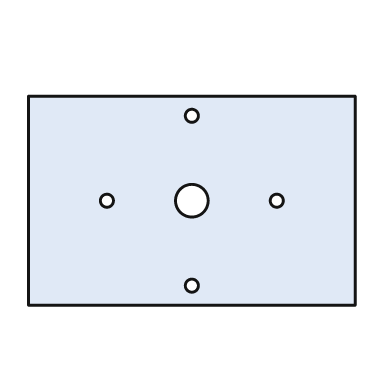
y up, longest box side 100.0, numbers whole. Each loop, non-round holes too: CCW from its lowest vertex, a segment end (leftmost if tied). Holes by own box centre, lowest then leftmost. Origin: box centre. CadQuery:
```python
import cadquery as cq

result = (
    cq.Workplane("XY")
    .moveTo(-50.0, -32.0)
    .lineTo(50.0, -32.0)
    .lineTo(50.0, 32.0)
    .lineTo(-50.0, 32.0)
    .close()
    .moveTo(0.0, -26.0)
    .circle(2.0)
    .moveTo(-26.0, 0.0)
    .circle(2.0)
    .moveTo(0.0, 0.0)
    .circle(5.0)
    .moveTo(26.0, 0.0)
    .circle(2.0)
    .moveTo(0.0, 26.0)
    .circle(2.0)
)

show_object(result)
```